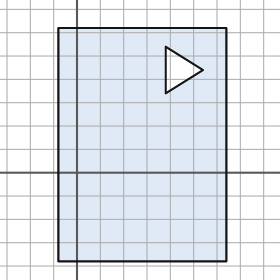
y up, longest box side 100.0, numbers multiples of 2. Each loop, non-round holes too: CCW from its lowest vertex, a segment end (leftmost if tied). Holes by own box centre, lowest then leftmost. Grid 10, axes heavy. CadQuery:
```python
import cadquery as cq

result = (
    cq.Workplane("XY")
    .moveTo(-8.0, -38.0)
    .lineTo(64.0, -38.0)
    .lineTo(64.0, 62.0)
    .lineTo(-8.0, 62.0)
    .close()
    .moveTo(38.0, 34.0)
    .lineTo(54.0, 44.0)
    .lineTo(38.0, 54.0)
    .close()
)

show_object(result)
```